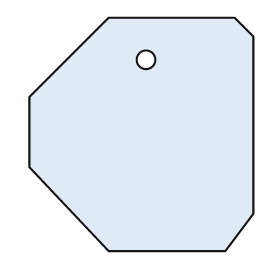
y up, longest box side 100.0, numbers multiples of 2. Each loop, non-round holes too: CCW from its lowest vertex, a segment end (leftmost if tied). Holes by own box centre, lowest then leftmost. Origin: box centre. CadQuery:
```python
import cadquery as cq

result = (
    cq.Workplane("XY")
    .moveTo(-14.0, -50.0)
    .lineTo(36.0, -50.0)
    .lineTo(48.0, -34.0)
    .lineTo(48.0, 42.0)
    .lineTo(40.0, 50.0)
    .lineTo(-14.0, 50.0)
    .lineTo(-48.0, 16.0)
    .lineTo(-48.0, -14.0)
    .close()
    .moveTo(2.0, 32.0)
    .circle(4.0)
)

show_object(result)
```